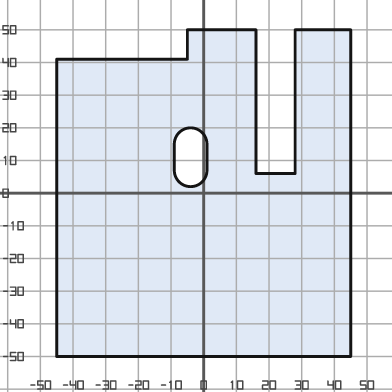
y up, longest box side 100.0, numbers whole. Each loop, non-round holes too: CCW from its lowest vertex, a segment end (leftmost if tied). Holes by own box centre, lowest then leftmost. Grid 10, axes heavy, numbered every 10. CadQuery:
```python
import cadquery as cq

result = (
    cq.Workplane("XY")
    .moveTo(-45.0, -50.0)
    .lineTo(45.0, -50.0)
    .lineTo(45.0, 50.0)
    .lineTo(28.0, 50.0)
    .lineTo(28.0, 6.0)
    .lineTo(16.0, 6.0)
    .lineTo(16.0, 50.0)
    .lineTo(-5.0, 50.0)
    .lineTo(-5.0, 41.0)
    .lineTo(-45.0, 41.0)
    .close()
    .moveTo(-9.0, 7.0)
    .threePointArc((-4.0, 2.0), (1.0, 7.0))
    .lineTo(1.0, 15.0)
    .threePointArc((-4.0, 20.0), (-9.0, 15.0))
    .close()
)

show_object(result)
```